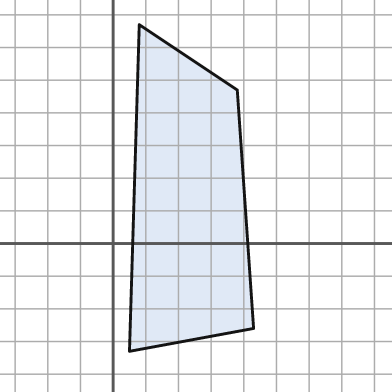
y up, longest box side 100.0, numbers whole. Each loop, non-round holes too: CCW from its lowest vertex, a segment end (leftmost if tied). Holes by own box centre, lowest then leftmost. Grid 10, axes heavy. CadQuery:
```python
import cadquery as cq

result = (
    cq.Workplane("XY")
    .moveTo(5.0, -33.0)
    .lineTo(43.0, -26.0)
    .lineTo(38.0, 47.0)
    .lineTo(8.0, 67.0)
    .close()
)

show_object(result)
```